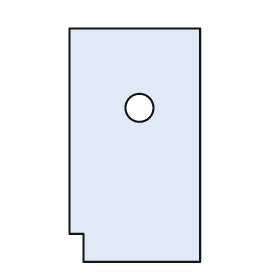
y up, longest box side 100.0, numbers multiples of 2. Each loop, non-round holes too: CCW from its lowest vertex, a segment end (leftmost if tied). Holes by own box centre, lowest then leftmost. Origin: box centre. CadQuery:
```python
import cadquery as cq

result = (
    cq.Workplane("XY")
    .moveTo(-22.0, -50.0)
    .lineTo(28.0, -50.0)
    .lineTo(28.0, 50.0)
    .lineTo(-28.0, 50.0)
    .lineTo(-28.0, -38.0)
    .lineTo(-22.0, -38.0)
    .close()
    .moveTo(2.0, 16.0)
    .circle(6.0)
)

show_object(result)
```